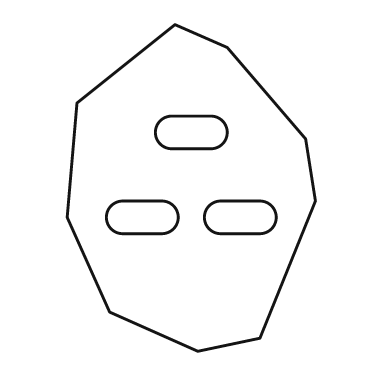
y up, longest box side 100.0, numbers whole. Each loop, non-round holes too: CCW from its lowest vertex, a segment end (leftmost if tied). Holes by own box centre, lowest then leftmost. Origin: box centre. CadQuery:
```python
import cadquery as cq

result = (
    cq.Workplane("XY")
    .moveTo(2.0, -50.0)
    .lineTo(21.0, -46.0)
    .lineTo(38.0, -4.0)
    .lineTo(35.0, 15.0)
    .lineTo(11.0, 43.0)
    .lineTo(-5.0, 50.0)
    .lineTo(-35.0, 26.0)
    .lineTo(-38.0, -9.0)
    .lineTo(-25.0, -38.0)
    .close()
    .moveTo(-21.0, -14.0)
    .lineTo(-9.0, -14.0)
    .threePointArc((-4.0, -9.0), (-9.0, -4.0))
    .lineTo(-21.0, -4.0)
    .threePointArc((-26.0, -9.0), (-21.0, -14.0))
    .close()
    .moveTo(9.0, -14.0)
    .lineTo(21.0, -14.0)
    .threePointArc((26.0, -9.0), (21.0, -4.0))
    .lineTo(9.0, -4.0)
    .threePointArc((4.0, -9.0), (9.0, -14.0))
    .close()
    .moveTo(-6.0, 12.0)
    .lineTo(6.0, 12.0)
    .threePointArc((11.0, 17.0), (6.0, 22.0))
    .lineTo(-6.0, 22.0)
    .threePointArc((-11.0, 17.0), (-6.0, 12.0))
    .close()
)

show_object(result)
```